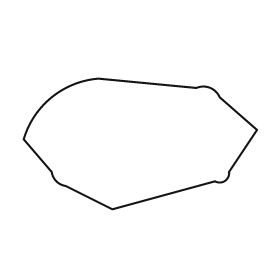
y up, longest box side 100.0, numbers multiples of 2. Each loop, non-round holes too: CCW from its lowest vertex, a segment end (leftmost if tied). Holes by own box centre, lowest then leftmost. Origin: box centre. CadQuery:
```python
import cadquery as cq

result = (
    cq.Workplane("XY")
    .moveTo(-12.0, -28.0)
    .lineTo(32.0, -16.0)
    .threePointArc((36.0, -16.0), (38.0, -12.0))
    .lineTo(50.0, 6.0)
    .lineTo(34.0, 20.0)
    .threePointArc((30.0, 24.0), (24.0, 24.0))
    .lineTo(-18.0, 28.0)
    .threePointArc((-38.0, 20.0), (-50.0, 2.0))
    .lineTo(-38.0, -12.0)
    .threePointArc((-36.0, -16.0), (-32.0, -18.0))
    .close()
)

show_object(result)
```